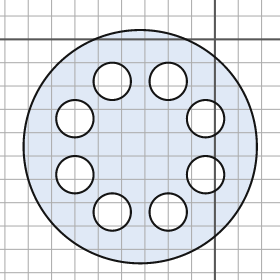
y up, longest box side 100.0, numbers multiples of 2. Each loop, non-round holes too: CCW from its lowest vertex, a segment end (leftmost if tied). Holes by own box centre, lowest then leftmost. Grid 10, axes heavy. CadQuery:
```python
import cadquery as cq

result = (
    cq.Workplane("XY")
    .moveTo(-32.0, -46.0)
    .circle(50.0)
    .moveTo(-44.0, -74.0)
    .circle(8.0)
    .moveTo(-20.0, -74.0)
    .circle(8.0)
    .moveTo(-60.0, -58.0)
    .circle(8.0)
    .moveTo(-4.0, -58.0)
    .circle(8.0)
    .moveTo(-60.0, -34.0)
    .circle(8.0)
    .moveTo(-4.0, -34.0)
    .circle(8.0)
    .moveTo(-44.0, -18.0)
    .circle(8.0)
    .moveTo(-20.0, -18.0)
    .circle(8.0)
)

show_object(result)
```